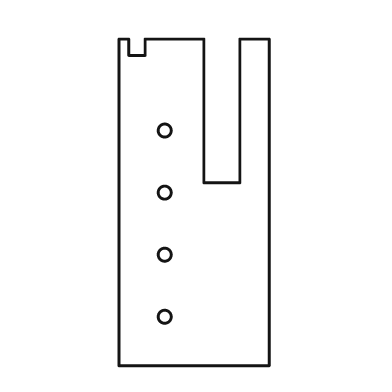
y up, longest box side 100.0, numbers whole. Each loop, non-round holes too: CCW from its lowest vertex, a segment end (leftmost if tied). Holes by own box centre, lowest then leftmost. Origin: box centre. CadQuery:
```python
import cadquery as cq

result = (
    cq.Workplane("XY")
    .moveTo(-23.0, -50.0)
    .lineTo(23.0, -50.0)
    .lineTo(23.0, 50.0)
    .lineTo(14.0, 50.0)
    .lineTo(14.0, 6.0)
    .lineTo(3.0, 6.0)
    .lineTo(3.0, 50.0)
    .lineTo(-15.0, 50.0)
    .lineTo(-15.0, 45.0)
    .lineTo(-20.0, 45.0)
    .lineTo(-20.0, 50.0)
    .lineTo(-23.0, 50.0)
    .close()
    .moveTo(-9.0, -35.0)
    .circle(2.0)
    .moveTo(-9.0, -16.0)
    .circle(2.0)
    .moveTo(-9.0, 3.0)
    .circle(2.0)
    .moveTo(-9.0, 22.0)
    .circle(2.0)
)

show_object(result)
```